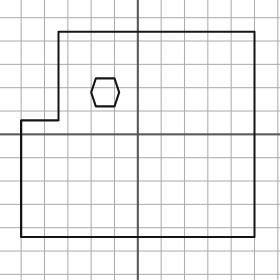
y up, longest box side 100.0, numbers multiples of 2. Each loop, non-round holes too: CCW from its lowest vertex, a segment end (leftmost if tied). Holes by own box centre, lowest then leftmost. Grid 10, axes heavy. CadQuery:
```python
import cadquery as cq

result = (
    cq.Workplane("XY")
    .moveTo(-50.0, -44.0)
    .lineTo(50.0, -44.0)
    .lineTo(50.0, 44.0)
    .lineTo(-34.0, 44.0)
    .lineTo(-34.0, 6.0)
    .lineTo(-50.0, 6.0)
    .close()
    .moveTo(-18.0, 12.0)
    .lineTo(-10.0, 12.0)
    .lineTo(-8.0, 18.0)
    .lineTo(-10.0, 24.0)
    .lineTo(-18.0, 24.0)
    .lineTo(-20.0, 18.0)
    .close()
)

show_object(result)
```